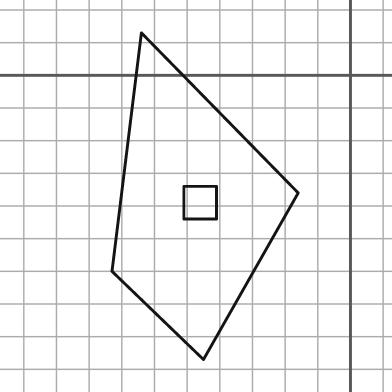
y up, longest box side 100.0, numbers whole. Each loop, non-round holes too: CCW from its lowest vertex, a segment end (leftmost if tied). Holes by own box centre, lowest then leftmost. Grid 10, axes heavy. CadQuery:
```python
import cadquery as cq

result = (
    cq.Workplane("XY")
    .moveTo(-45.0, -87.0)
    .lineTo(-16.0, -36.0)
    .lineTo(-64.0, 13.0)
    .lineTo(-73.0, -60.0)
    .close()
    .moveTo(-51.0, -44.0)
    .lineTo(-41.0, -44.0)
    .lineTo(-41.0, -34.0)
    .lineTo(-51.0, -34.0)
    .close()
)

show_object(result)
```